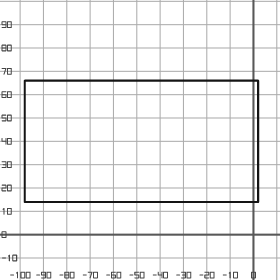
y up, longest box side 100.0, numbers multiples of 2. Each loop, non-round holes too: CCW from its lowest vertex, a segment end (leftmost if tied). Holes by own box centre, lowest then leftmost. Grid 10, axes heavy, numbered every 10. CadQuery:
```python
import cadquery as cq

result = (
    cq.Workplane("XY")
    .moveTo(-98.0, 14.0)
    .lineTo(2.0, 14.0)
    .lineTo(2.0, 66.0)
    .lineTo(-98.0, 66.0)
    .close()
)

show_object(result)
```